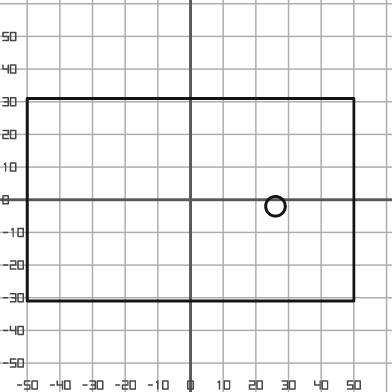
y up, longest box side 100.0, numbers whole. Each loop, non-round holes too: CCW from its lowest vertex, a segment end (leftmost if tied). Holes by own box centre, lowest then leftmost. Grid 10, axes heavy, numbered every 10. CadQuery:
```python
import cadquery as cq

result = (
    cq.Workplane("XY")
    .moveTo(-50.0, -31.0)
    .lineTo(50.0, -31.0)
    .lineTo(50.0, 31.0)
    .lineTo(-50.0, 31.0)
    .close()
    .moveTo(26.0, -2.0)
    .circle(3.0)
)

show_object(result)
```